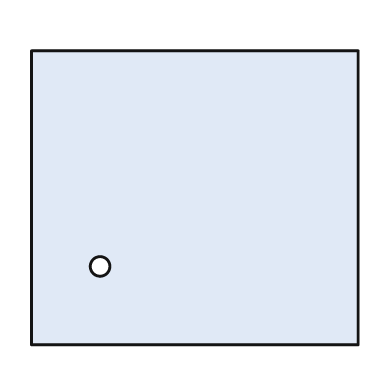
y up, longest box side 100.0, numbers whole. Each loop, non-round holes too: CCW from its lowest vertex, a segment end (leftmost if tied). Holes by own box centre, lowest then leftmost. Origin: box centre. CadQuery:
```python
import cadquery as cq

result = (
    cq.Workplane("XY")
    .moveTo(-50.0, -45.0)
    .lineTo(50.0, -45.0)
    .lineTo(50.0, 45.0)
    .lineTo(-50.0, 45.0)
    .close()
    .moveTo(-29.0, -21.0)
    .circle(3.0)
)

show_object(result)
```